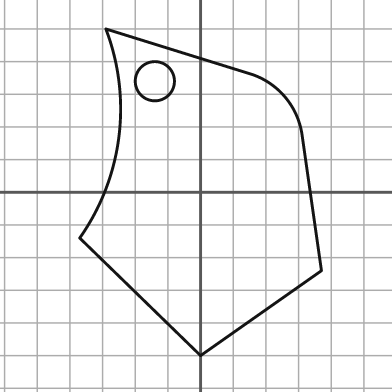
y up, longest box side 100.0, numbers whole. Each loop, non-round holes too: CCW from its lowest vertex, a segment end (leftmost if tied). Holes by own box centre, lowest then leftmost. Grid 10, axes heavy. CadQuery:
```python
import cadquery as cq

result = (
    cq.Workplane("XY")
    .moveTo(0.0, -50.0)
    .lineTo(37.0, -24.0)
    .lineTo(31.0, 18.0)
    .threePointArc((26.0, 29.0), (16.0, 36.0))
    .lineTo(-29.0, 50.0)
    .threePointArc((-25.0, 17.0), (-37.0, -14.0))
    .close()
    .moveTo(-14.0, 34.0)
    .circle(6.0)
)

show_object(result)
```